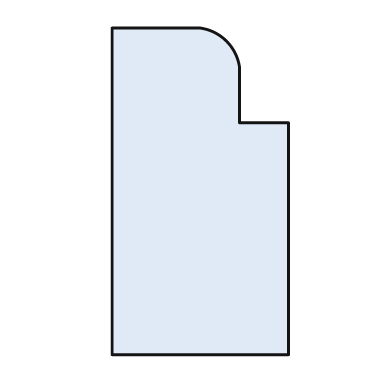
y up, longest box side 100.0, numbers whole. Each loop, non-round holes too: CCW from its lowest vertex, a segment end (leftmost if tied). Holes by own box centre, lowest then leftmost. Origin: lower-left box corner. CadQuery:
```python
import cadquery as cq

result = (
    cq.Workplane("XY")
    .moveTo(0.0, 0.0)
    .lineTo(54.0, 0.0)
    .lineTo(54.0, 71.0)
    .lineTo(39.0, 71.0)
    .lineTo(39.0, 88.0)
    .threePointArc((35.0, 96.0), (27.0, 100.0))
    .lineTo(0.0, 100.0)
    .close()
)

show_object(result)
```